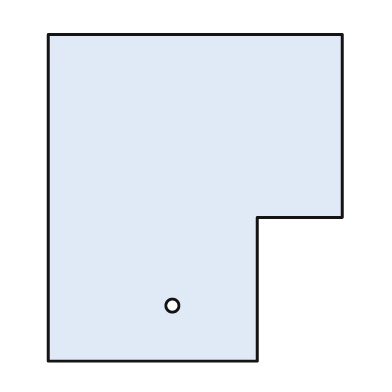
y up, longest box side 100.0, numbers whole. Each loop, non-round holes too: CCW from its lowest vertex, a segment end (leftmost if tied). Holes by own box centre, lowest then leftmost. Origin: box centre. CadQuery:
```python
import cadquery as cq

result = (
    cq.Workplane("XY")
    .moveTo(-45.0, -50.0)
    .lineTo(19.0, -50.0)
    .lineTo(19.0, -6.0)
    .lineTo(45.0, -6.0)
    .lineTo(45.0, 50.0)
    .lineTo(-45.0, 50.0)
    .close()
    .moveTo(-7.0, -33.0)
    .circle(2.0)
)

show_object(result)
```